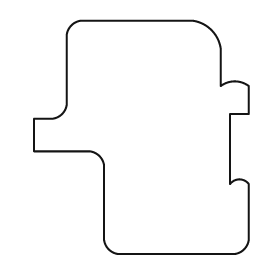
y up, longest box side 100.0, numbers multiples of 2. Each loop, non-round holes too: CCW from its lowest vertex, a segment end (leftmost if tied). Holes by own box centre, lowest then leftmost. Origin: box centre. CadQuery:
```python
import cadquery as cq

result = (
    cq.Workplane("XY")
    .moveTo(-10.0, -50.0)
    .lineTo(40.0, -50.0)
    .threePointArc((44.0, -48.0), (46.0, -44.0))
    .lineTo(46.0, -20.0)
    .threePointArc((42.0, -18.0), (38.0, -20.0))
    .lineTo(38.0, 10.0)
    .lineTo(46.0, 10.0)
    .lineTo(46.0, 22.0)
    .threePointArc((40.0, 24.0), (34.0, 22.0))
    .lineTo(34.0, 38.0)
    .threePointArc((30.0, 46.0), (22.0, 50.0))
    .lineTo(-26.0, 50.0)
    .threePointArc((-30.0, 48.0), (-32.0, 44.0))
    .lineTo(-32.0, 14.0)
    .threePointArc((-34.0, 10.0), (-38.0, 8.0))
    .lineTo(-46.0, 8.0)
    .lineTo(-46.0, -6.0)
    .lineTo(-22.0, -6.0)
    .threePointArc((-18.0, -8.0), (-16.0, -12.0))
    .lineTo(-16.0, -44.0)
    .threePointArc((-14.0, -48.0), (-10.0, -50.0))
    .close()
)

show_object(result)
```